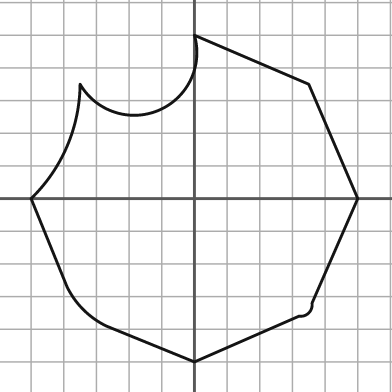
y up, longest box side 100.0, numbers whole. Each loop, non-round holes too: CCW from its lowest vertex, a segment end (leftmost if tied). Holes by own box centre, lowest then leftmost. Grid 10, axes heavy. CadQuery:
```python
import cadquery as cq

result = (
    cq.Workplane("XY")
    .moveTo(0.0, -50.0)
    .lineTo(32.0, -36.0)
    .threePointArc((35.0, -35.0), (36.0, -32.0))
    .lineTo(50.0, 0.0)
    .lineTo(35.0, 35.0)
    .lineTo(0.0, 50.0)
    .threePointArc((-11.0, 27.0), (-35.0, 35.0))
    .threePointArc((-39.0, 16.0), (-50.0, 0.0))
    .lineTo(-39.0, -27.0)
    .threePointArc((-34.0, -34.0), (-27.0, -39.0))
    .close()
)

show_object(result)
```